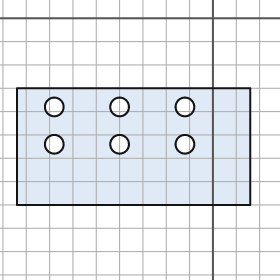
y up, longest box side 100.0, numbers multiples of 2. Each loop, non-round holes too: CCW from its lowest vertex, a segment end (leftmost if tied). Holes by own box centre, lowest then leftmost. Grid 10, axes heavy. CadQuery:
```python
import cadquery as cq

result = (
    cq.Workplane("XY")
    .moveTo(-84.0, -80.0)
    .lineTo(16.0, -80.0)
    .lineTo(16.0, -30.0)
    .lineTo(-84.0, -30.0)
    .close()
    .moveTo(-68.0, -54.0)
    .circle(4.0)
    .moveTo(-40.0, -54.0)
    .circle(4.0)
    .moveTo(-12.0, -54.0)
    .circle(4.0)
    .moveTo(-68.0, -38.0)
    .circle(4.0)
    .moveTo(-40.0, -38.0)
    .circle(4.0)
    .moveTo(-12.0, -38.0)
    .circle(4.0)
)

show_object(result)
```